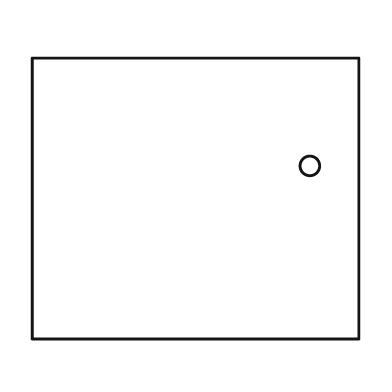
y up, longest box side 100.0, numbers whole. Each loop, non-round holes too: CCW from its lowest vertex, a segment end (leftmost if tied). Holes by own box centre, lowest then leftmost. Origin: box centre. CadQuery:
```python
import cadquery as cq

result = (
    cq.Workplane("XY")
    .moveTo(-50.0, -43.0)
    .lineTo(50.0, -43.0)
    .lineTo(50.0, 43.0)
    .lineTo(-50.0, 43.0)
    .close()
    .moveTo(35.0, 10.0)
    .circle(3.0)
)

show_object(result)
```